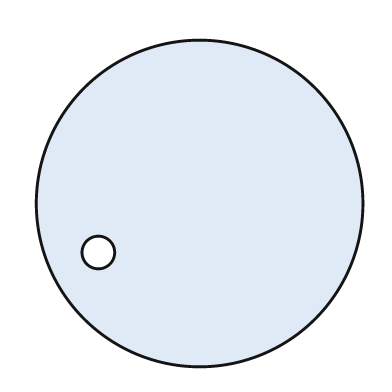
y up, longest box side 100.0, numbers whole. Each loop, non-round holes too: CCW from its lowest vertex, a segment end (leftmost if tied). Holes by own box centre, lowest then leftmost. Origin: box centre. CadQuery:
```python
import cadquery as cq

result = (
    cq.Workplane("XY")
    .moveTo(0.0, 0.0)
    .circle(50.0)
    .moveTo(-31.0, -15.0)
    .circle(5.0)
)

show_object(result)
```